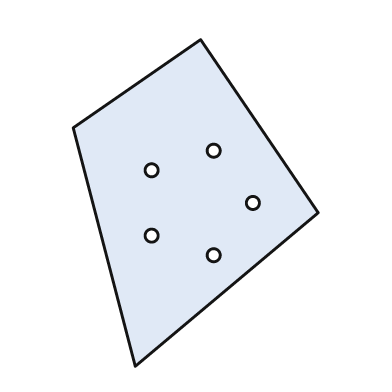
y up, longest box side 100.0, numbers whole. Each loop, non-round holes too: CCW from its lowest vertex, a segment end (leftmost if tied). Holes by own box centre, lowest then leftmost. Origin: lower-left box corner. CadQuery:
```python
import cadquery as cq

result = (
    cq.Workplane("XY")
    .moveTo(19.0, 0.0)
    .lineTo(75.0, 47.0)
    .lineTo(39.0, 100.0)
    .lineTo(0.0, 73.0)
    .close()
    .moveTo(43.0, 34.0)
    .circle(2.0)
    .moveTo(24.0, 40.0)
    .circle(2.0)
    .moveTo(55.0, 50.0)
    .circle(2.0)
    .moveTo(24.0, 60.0)
    .circle(2.0)
    .moveTo(43.0, 66.0)
    .circle(2.0)
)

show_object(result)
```